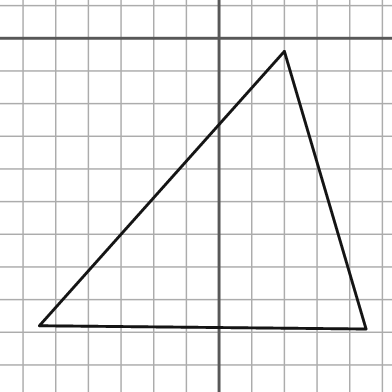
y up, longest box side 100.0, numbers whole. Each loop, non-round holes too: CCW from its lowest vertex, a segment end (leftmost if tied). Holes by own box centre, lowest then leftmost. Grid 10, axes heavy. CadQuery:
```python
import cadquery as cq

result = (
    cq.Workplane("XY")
    .moveTo(45.0, -89.0)
    .lineTo(20.0, -4.0)
    .lineTo(-55.0, -88.0)
    .close()
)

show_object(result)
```